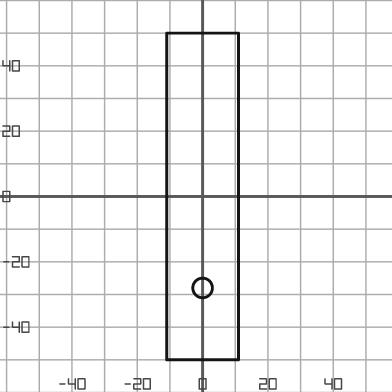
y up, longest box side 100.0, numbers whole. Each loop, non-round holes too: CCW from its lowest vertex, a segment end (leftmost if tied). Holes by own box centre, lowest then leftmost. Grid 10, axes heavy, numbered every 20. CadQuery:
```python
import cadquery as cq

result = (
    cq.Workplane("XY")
    .moveTo(-11.0, -50.0)
    .lineTo(11.0, -50.0)
    .lineTo(11.0, 50.0)
    .lineTo(-11.0, 50.0)
    .close()
    .moveTo(0.0, -28.0)
    .circle(3.0)
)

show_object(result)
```